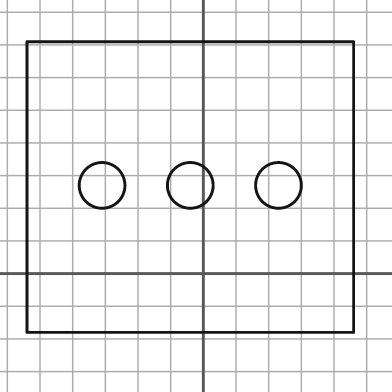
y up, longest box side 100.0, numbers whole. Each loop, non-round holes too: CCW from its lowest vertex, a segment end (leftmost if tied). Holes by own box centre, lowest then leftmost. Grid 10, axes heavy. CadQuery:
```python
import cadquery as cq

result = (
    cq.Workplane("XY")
    .moveTo(-54.0, -18.0)
    .lineTo(46.0, -18.0)
    .lineTo(46.0, 71.0)
    .lineTo(-54.0, 71.0)
    .close()
    .moveTo(-31.0, 27.0)
    .circle(7.0)
    .moveTo(-4.0, 27.0)
    .circle(7.0)
    .moveTo(23.0, 27.0)
    .circle(7.0)
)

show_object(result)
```